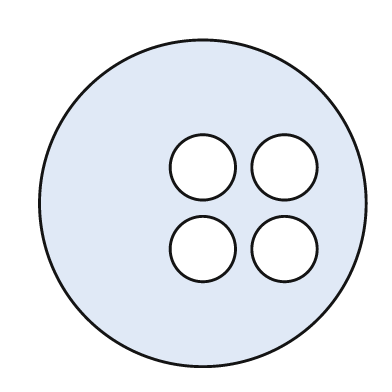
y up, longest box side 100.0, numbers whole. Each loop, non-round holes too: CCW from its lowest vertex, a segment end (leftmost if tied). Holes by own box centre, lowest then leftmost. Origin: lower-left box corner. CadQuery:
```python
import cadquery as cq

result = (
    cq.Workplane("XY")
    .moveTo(50.0, 50.0)
    .circle(50.0)
    .moveTo(50.0, 36.0)
    .circle(10.0)
    .moveTo(75.0, 36.0)
    .circle(10.0)
    .moveTo(50.0, 61.0)
    .circle(10.0)
    .moveTo(75.0, 61.0)
    .circle(10.0)
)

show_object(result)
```